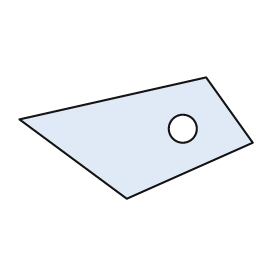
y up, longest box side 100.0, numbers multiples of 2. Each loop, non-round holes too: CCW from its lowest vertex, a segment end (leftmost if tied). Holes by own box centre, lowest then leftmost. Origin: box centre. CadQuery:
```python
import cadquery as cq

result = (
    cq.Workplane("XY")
    .moveTo(-4.0, -26.0)
    .lineTo(50.0, -2.0)
    .lineTo(30.0, 26.0)
    .lineTo(-50.0, 8.0)
    .close()
    .moveTo(20.0, 4.0)
    .circle(6.0)
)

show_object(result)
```